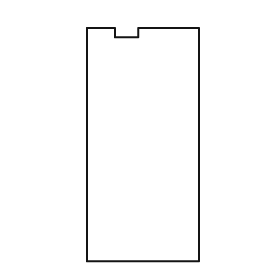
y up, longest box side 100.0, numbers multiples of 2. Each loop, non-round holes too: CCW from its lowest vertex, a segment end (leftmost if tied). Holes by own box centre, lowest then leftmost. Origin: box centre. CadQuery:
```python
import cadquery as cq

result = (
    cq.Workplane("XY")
    .moveTo(-24.0, -50.0)
    .lineTo(24.0, -50.0)
    .lineTo(24.0, 50.0)
    .lineTo(-2.0, 50.0)
    .lineTo(-2.0, 46.0)
    .lineTo(-12.0, 46.0)
    .lineTo(-12.0, 50.0)
    .lineTo(-24.0, 50.0)
    .close()
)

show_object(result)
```